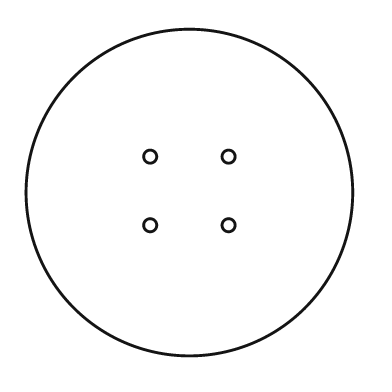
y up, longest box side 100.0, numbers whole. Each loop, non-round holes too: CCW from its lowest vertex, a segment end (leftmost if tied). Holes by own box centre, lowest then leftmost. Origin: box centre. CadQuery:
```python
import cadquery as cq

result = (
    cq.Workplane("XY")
    .moveTo(0.0, 0.0)
    .circle(50.0)
    .moveTo(-12.0, -10.0)
    .circle(2.0)
    .moveTo(12.0, -10.0)
    .circle(2.0)
    .moveTo(-12.0, 11.0)
    .circle(2.0)
    .moveTo(12.0, 11.0)
    .circle(2.0)
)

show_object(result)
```